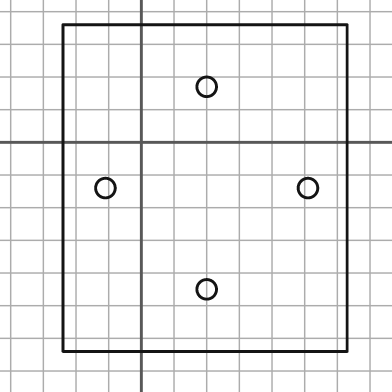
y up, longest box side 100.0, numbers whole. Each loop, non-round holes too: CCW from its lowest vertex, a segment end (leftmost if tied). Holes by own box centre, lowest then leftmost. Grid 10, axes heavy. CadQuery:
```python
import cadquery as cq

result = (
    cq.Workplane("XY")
    .moveTo(-24.0, -64.0)
    .lineTo(63.0, -64.0)
    .lineTo(63.0, 36.0)
    .lineTo(-24.0, 36.0)
    .close()
    .moveTo(20.0, -45.0)
    .circle(3.0)
    .moveTo(-11.0, -14.0)
    .circle(3.0)
    .moveTo(51.0, -14.0)
    .circle(3.0)
    .moveTo(20.0, 17.0)
    .circle(3.0)
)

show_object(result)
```